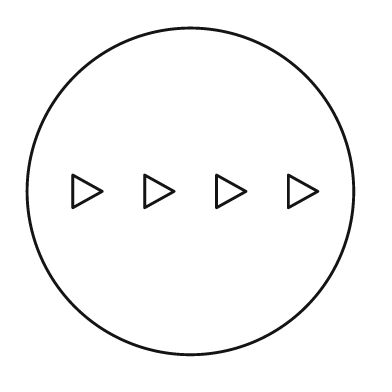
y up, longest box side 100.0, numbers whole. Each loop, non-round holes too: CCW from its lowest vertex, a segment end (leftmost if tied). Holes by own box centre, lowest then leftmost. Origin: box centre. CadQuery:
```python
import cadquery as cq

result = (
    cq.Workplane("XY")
    .moveTo(0.0, 0.0)
    .circle(50.0)
    .moveTo(-36.0, -5.0)
    .lineTo(-27.0, 0.0)
    .lineTo(-36.0, 5.0)
    .close()
    .moveTo(-14.0, -5.0)
    .lineTo(-5.0, 0.0)
    .lineTo(-14.0, 5.0)
    .close()
    .moveTo(8.0, -5.0)
    .lineTo(17.0, 0.0)
    .lineTo(8.0, 5.0)
    .close()
    .moveTo(30.0, -5.0)
    .lineTo(39.0, 0.0)
    .lineTo(30.0, 5.0)
    .close()
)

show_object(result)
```